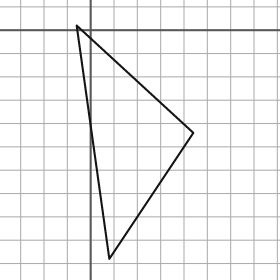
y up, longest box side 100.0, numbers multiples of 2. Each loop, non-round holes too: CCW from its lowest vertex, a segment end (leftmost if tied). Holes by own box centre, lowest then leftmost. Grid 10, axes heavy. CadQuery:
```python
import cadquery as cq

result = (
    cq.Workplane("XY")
    .moveTo(8.0, -98.0)
    .lineTo(44.0, -44.0)
    .lineTo(-6.0, 2.0)
    .close()
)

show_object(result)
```